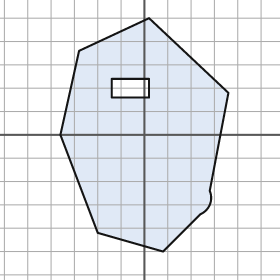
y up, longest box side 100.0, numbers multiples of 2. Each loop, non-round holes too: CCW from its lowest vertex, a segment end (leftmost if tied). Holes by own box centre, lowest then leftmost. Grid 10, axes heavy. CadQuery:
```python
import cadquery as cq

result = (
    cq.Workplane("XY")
    .moveTo(8.0, -50.0)
    .lineTo(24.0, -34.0)
    .threePointArc((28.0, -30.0), (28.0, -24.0))
    .lineTo(36.0, 18.0)
    .lineTo(2.0, 50.0)
    .lineTo(-28.0, 36.0)
    .lineTo(-36.0, 0.0)
    .lineTo(-20.0, -42.0)
    .close()
    .moveTo(-14.0, 16.0)
    .lineTo(2.0, 16.0)
    .lineTo(2.0, 24.0)
    .lineTo(-14.0, 24.0)
    .close()
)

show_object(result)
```